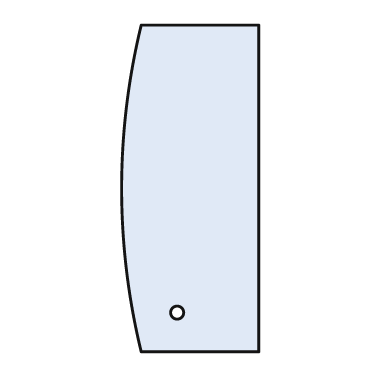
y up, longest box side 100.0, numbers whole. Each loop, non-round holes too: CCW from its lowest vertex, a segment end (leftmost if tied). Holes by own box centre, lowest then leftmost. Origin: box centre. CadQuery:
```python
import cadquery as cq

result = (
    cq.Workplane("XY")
    .moveTo(-15.0, -50.0)
    .lineTo(21.0, -50.0)
    .lineTo(21.0, 50.0)
    .lineTo(-15.0, 50.0)
    .threePointArc((-21.0, 0.0), (-15.0, -50.0))
    .close()
    .moveTo(-4.0, -38.0)
    .circle(2.0)
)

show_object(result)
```